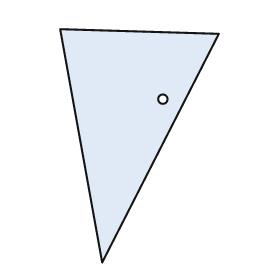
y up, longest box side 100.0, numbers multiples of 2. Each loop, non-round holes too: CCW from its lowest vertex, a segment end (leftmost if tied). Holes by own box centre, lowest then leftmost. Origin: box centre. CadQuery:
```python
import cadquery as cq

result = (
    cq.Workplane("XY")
    .moveTo(-16.0, -50.0)
    .lineTo(34.0, 48.0)
    .lineTo(-34.0, 50.0)
    .close()
    .moveTo(10.0, 20.0)
    .circle(2.0)
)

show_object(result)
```